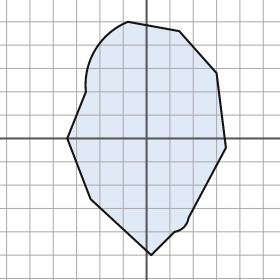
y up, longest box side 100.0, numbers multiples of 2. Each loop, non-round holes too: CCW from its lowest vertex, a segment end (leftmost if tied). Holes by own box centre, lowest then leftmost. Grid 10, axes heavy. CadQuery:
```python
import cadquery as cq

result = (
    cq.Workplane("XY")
    .moveTo(2.0, -50.0)
    .lineTo(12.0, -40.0)
    .threePointArc((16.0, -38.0), (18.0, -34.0))
    .lineTo(34.0, -4.0)
    .lineTo(30.0, 28.0)
    .lineTo(14.0, 46.0)
    .lineTo(-8.0, 50.0)
    .threePointArc((-22.0, 38.0), (-26.0, 20.0))
    .lineTo(-34.0, 0.0)
    .lineTo(-24.0, -26.0)
    .close()
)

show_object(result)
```